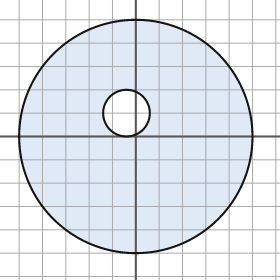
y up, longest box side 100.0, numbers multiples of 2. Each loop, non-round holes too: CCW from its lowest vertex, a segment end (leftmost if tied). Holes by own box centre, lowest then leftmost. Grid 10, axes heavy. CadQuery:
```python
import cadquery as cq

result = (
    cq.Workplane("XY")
    .moveTo(0.0, 0.0)
    .circle(50.0)
    .moveTo(-4.0, 10.0)
    .circle(10.0)
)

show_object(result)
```